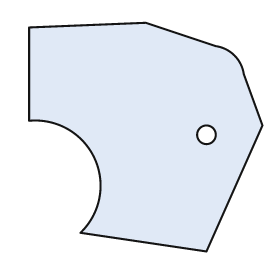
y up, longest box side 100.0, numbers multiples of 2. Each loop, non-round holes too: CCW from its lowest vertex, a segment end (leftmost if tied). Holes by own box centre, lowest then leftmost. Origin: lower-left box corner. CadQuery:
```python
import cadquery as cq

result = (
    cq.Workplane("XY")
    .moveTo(76.0, 0.0)
    .lineTo(100.0, 54.0)
    .lineTo(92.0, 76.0)
    .threePointArc((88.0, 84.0), (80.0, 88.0))
    .lineTo(50.0, 98.0)
    .lineTo(0.0, 96.0)
    .lineTo(0.0, 56.0)
    .threePointArc((28.0, 40.0), (22.0, 8.0))
    .close()
    .moveTo(76.0, 50.0)
    .circle(4.0)
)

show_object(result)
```